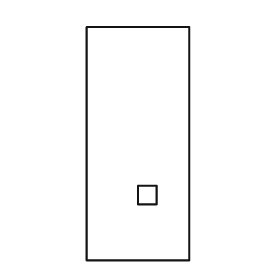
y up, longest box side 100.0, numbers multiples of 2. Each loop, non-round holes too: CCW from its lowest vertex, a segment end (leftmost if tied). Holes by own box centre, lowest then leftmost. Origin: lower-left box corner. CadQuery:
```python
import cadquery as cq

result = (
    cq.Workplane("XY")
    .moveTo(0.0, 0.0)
    .lineTo(44.0, 0.0)
    .lineTo(44.0, 100.0)
    .lineTo(0.0, 100.0)
    .close()
    .moveTo(22.0, 24.0)
    .lineTo(30.0, 24.0)
    .lineTo(30.0, 32.0)
    .lineTo(22.0, 32.0)
    .close()
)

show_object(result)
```